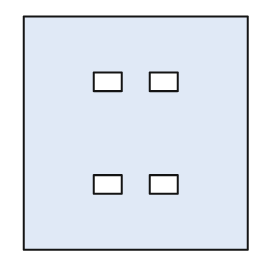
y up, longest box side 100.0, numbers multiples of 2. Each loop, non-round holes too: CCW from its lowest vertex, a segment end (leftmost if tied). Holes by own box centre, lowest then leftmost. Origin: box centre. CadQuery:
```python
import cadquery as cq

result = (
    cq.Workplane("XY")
    .moveTo(-48.0, -50.0)
    .lineTo(48.0, -50.0)
    .lineTo(48.0, 50.0)
    .lineTo(-48.0, 50.0)
    .close()
    .moveTo(-18.0, -26.0)
    .lineTo(-6.0, -26.0)
    .lineTo(-6.0, -18.0)
    .lineTo(-18.0, -18.0)
    .close()
    .moveTo(6.0, -26.0)
    .lineTo(18.0, -26.0)
    .lineTo(18.0, -18.0)
    .lineTo(6.0, -18.0)
    .close()
    .moveTo(-18.0, 18.0)
    .lineTo(-6.0, 18.0)
    .lineTo(-6.0, 26.0)
    .lineTo(-18.0, 26.0)
    .close()
    .moveTo(6.0, 18.0)
    .lineTo(18.0, 18.0)
    .lineTo(18.0, 26.0)
    .lineTo(6.0, 26.0)
    .close()
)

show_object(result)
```